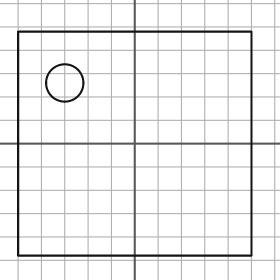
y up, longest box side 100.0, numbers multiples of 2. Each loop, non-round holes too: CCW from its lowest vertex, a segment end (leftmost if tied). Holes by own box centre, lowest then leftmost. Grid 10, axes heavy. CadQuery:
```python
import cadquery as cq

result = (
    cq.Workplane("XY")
    .moveTo(-50.0, -48.0)
    .lineTo(50.0, -48.0)
    .lineTo(50.0, 48.0)
    .lineTo(-50.0, 48.0)
    .close()
    .moveTo(-30.0, 26.0)
    .circle(8.0)
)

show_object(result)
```